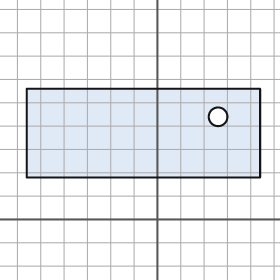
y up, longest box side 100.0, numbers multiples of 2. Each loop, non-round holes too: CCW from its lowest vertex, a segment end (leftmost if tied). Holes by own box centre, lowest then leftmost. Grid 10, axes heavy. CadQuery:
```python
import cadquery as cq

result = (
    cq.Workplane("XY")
    .moveTo(-56.0, 18.0)
    .lineTo(44.0, 18.0)
    .lineTo(44.0, 56.0)
    .lineTo(-56.0, 56.0)
    .close()
    .moveTo(26.0, 44.0)
    .circle(4.0)
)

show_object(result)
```